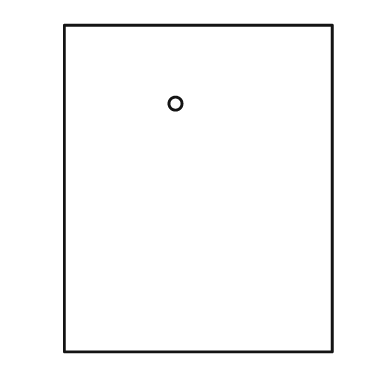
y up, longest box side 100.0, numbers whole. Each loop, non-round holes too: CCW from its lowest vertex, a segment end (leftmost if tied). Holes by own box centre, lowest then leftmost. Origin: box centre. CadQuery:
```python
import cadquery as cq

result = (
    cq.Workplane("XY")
    .moveTo(-41.0, -50.0)
    .lineTo(41.0, -50.0)
    .lineTo(41.0, 50.0)
    .lineTo(-41.0, 50.0)
    .close()
    .moveTo(-7.0, 26.0)
    .circle(2.0)
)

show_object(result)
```